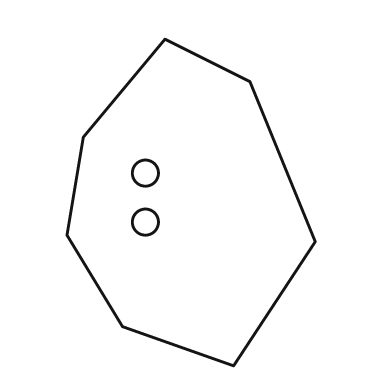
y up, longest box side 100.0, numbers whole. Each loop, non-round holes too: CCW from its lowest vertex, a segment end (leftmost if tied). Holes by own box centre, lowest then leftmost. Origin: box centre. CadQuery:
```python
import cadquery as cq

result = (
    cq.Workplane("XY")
    .moveTo(13.0, -50.0)
    .lineTo(38.0, -12.0)
    .lineTo(18.0, 37.0)
    .lineTo(-8.0, 50.0)
    .lineTo(-33.0, 20.0)
    .lineTo(-38.0, -10.0)
    .lineTo(-21.0, -38.0)
    .close()
    .moveTo(-14.0, -6.0)
    .circle(4.0)
    .moveTo(-14.0, 9.0)
    .circle(4.0)
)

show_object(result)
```